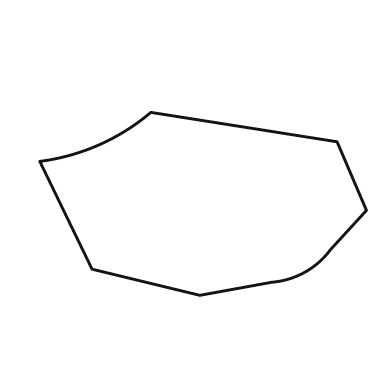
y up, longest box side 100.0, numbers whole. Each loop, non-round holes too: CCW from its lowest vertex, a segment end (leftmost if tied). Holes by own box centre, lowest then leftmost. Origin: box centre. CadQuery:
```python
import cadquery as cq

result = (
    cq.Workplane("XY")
    .moveTo(-1.0, -28.0)
    .lineTo(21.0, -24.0)
    .threePointArc((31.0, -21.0), (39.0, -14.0))
    .lineTo(50.0, -2.0)
    .lineTo(41.0, 19.0)
    .lineTo(-16.0, 28.0)
    .threePointArc((-32.0, 18.0), (-50.0, 13.0))
    .lineTo(-34.0, -20.0)
    .close()
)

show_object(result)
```